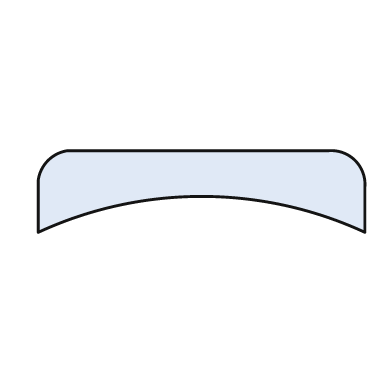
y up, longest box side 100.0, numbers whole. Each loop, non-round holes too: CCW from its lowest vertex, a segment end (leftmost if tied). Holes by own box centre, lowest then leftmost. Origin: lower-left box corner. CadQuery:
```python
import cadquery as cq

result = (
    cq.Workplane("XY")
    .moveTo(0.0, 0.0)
    .threePointArc((50.0, 11.0), (100.0, 0.0))
    .lineTo(100.0, 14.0)
    .threePointArc((97.0, 22.0), (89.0, 25.0))
    .lineTo(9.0, 25.0)
    .threePointArc((3.0, 22.0), (0.0, 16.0))
    .close()
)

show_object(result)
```